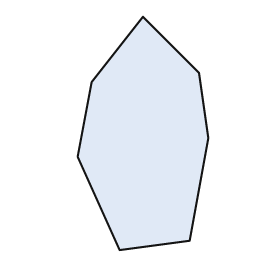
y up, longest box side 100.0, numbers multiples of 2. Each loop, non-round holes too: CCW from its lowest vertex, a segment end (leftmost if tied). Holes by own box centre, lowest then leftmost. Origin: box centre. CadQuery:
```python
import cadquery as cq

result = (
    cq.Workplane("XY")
    .moveTo(-10.0, -50.0)
    .lineTo(20.0, -46.0)
    .lineTo(28.0, -2.0)
    .lineTo(24.0, 26.0)
    .lineTo(0.0, 50.0)
    .lineTo(-22.0, 22.0)
    .lineTo(-28.0, -10.0)
    .close()
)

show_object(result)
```